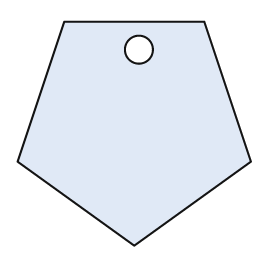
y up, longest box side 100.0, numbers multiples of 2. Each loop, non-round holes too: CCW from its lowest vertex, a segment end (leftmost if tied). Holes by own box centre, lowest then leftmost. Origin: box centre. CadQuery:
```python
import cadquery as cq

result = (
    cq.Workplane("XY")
    .moveTo(0.0, -48.0)
    .lineTo(50.0, -12.0)
    .lineTo(30.0, 48.0)
    .lineTo(-30.0, 48.0)
    .lineTo(-50.0, -12.0)
    .close()
    .moveTo(2.0, 36.0)
    .circle(6.0)
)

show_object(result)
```